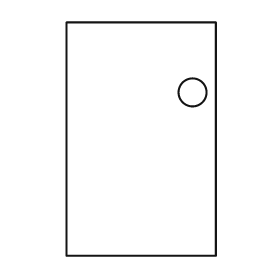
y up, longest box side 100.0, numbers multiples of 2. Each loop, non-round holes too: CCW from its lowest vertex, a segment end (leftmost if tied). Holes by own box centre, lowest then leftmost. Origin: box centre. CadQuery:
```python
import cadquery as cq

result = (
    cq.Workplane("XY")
    .moveTo(-32.0, -50.0)
    .lineTo(32.0, -50.0)
    .lineTo(32.0, 50.0)
    .lineTo(-32.0, 50.0)
    .close()
    .moveTo(22.0, 20.0)
    .circle(6.0)
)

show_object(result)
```